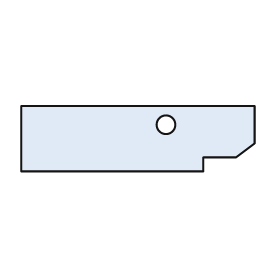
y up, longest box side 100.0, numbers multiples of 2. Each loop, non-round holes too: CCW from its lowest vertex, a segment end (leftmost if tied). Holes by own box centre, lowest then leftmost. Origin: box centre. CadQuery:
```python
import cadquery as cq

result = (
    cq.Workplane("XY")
    .moveTo(-50.0, -14.0)
    .lineTo(28.0, -14.0)
    .lineTo(28.0, -8.0)
    .lineTo(42.0, -8.0)
    .lineTo(50.0, -2.0)
    .lineTo(50.0, 14.0)
    .lineTo(-50.0, 14.0)
    .close()
    .moveTo(12.0, 6.0)
    .circle(4.0)
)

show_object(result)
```